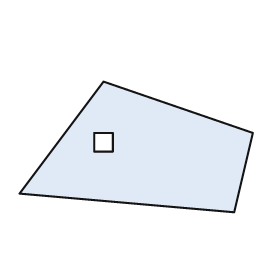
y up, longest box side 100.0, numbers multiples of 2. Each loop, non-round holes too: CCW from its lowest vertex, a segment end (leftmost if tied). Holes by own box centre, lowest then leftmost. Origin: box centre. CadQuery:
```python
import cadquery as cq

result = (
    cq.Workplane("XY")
    .moveTo(42.0, -28.0)
    .lineTo(50.0, 6.0)
    .lineTo(-14.0, 28.0)
    .lineTo(-50.0, -20.0)
    .close()
    .moveTo(-18.0, -2.0)
    .lineTo(-10.0, -2.0)
    .lineTo(-10.0, 6.0)
    .lineTo(-18.0, 6.0)
    .close()
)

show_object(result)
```